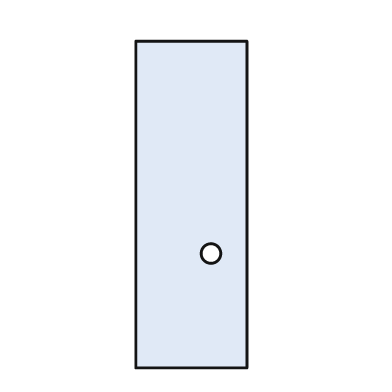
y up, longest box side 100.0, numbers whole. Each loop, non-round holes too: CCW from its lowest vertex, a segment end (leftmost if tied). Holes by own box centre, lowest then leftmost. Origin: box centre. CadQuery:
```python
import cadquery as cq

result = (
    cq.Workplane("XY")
    .moveTo(-17.0, -50.0)
    .lineTo(17.0, -50.0)
    .lineTo(17.0, 50.0)
    .lineTo(-17.0, 50.0)
    .close()
    .moveTo(6.0, -15.0)
    .circle(3.0)
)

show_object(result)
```